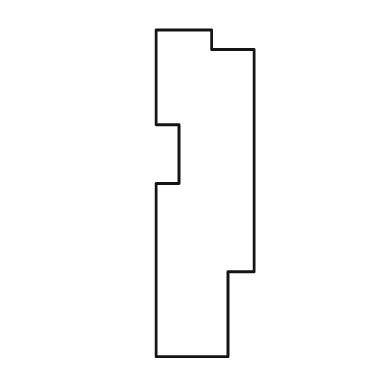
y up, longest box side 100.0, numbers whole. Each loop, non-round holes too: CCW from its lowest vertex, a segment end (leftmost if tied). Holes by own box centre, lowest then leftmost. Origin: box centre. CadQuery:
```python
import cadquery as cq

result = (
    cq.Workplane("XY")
    .moveTo(-15.0, -50.0)
    .lineTo(7.0, -50.0)
    .lineTo(7.0, -24.0)
    .lineTo(15.0, -24.0)
    .lineTo(15.0, 44.0)
    .lineTo(2.0, 44.0)
    .lineTo(2.0, 50.0)
    .lineTo(-15.0, 50.0)
    .lineTo(-15.0, 21.0)
    .lineTo(-8.0, 21.0)
    .lineTo(-8.0, 3.0)
    .lineTo(-15.0, 3.0)
    .close()
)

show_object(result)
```